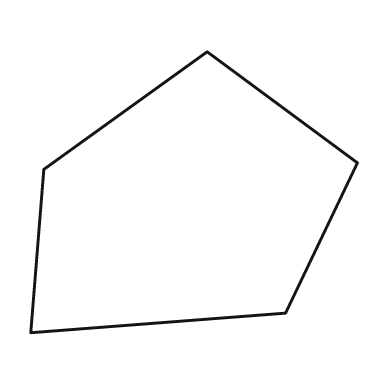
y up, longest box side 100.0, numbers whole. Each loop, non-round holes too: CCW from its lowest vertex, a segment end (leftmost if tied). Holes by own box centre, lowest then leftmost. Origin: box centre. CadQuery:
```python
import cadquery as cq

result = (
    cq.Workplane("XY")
    .moveTo(-50.0, -43.0)
    .lineTo(28.0, -37.0)
    .lineTo(50.0, 9.0)
    .lineTo(4.0, 43.0)
    .lineTo(-46.0, 7.0)
    .close()
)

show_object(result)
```